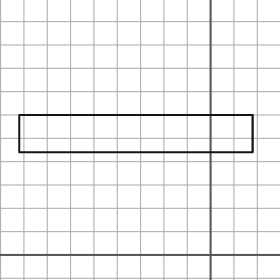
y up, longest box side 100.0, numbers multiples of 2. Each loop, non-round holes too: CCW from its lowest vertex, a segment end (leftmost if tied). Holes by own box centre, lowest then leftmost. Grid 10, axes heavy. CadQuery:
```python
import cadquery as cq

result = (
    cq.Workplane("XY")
    .moveTo(-82.0, 44.0)
    .lineTo(18.0, 44.0)
    .lineTo(18.0, 60.0)
    .lineTo(-82.0, 60.0)
    .close()
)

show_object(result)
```